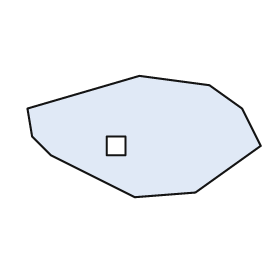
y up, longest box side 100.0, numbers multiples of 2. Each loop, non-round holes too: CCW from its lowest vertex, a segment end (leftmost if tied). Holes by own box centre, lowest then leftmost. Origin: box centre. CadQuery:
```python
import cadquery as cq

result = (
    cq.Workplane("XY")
    .moveTo(-4.0, -26.0)
    .lineTo(22.0, -24.0)
    .lineTo(50.0, -4.0)
    .lineTo(42.0, 12.0)
    .lineTo(28.0, 22.0)
    .lineTo(-2.0, 26.0)
    .lineTo(-50.0, 12.0)
    .lineTo(-48.0, 0.0)
    .lineTo(-40.0, -8.0)
    .close()
    .moveTo(-16.0, -8.0)
    .lineTo(-8.0, -8.0)
    .lineTo(-8.0, 0.0)
    .lineTo(-16.0, 0.0)
    .close()
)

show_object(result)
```